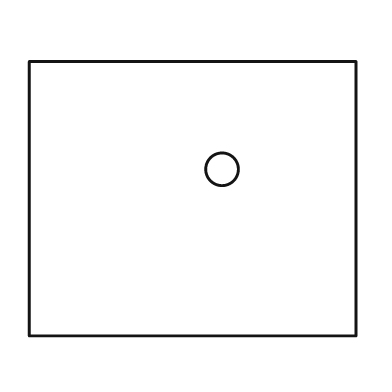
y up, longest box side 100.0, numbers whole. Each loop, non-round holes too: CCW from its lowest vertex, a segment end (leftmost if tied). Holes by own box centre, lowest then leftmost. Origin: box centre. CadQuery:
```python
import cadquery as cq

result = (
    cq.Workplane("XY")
    .moveTo(-50.0, -42.0)
    .lineTo(50.0, -42.0)
    .lineTo(50.0, 42.0)
    .lineTo(-50.0, 42.0)
    .close()
    .moveTo(9.0, 9.0)
    .circle(5.0)
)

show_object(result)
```